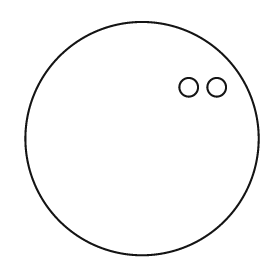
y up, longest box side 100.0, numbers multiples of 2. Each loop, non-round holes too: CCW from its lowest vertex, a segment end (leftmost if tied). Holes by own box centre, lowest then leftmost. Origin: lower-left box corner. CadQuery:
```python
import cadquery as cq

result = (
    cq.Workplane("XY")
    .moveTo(50.0, 50.0)
    .circle(50.0)
    .moveTo(70.0, 72.0)
    .circle(4.0)
    .moveTo(82.0, 72.0)
    .circle(4.0)
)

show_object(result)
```